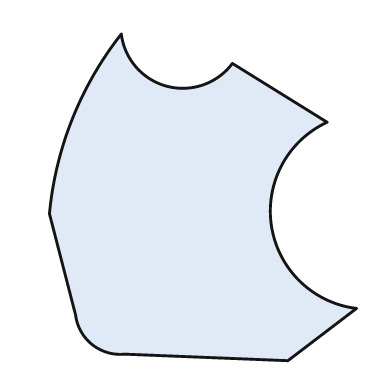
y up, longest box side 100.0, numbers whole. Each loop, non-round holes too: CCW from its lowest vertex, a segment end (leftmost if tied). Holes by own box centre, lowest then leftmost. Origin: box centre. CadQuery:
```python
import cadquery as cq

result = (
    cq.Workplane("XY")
    .moveTo(26.0, -50.0)
    .lineTo(47.0, -34.0)
    .threePointArc((21.0, -9.0), (38.0, 23.0))
    .lineTo(9.0, 41.0)
    .threePointArc((-11.0, 34.0), (-25.0, 50.0))
    .threePointArc((-40.0, 24.0), (-47.0, -5.0))
    .lineTo(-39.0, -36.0)
    .threePointArc((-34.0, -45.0), (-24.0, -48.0))
    .close()
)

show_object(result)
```